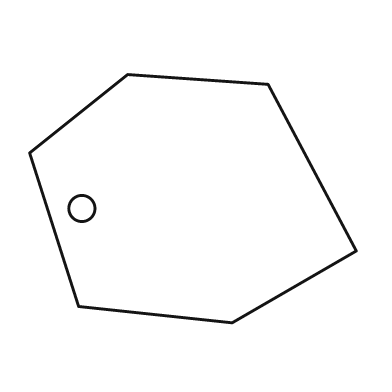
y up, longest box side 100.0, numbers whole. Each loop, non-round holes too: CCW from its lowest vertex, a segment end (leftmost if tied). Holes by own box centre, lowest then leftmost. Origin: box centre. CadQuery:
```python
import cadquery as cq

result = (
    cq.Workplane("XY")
    .moveTo(12.0, -38.0)
    .lineTo(50.0, -16.0)
    .lineTo(23.0, 35.0)
    .lineTo(-20.0, 38.0)
    .lineTo(-50.0, 14.0)
    .lineTo(-35.0, -33.0)
    .close()
    .moveTo(-34.0, -3.0)
    .circle(4.0)
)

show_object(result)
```